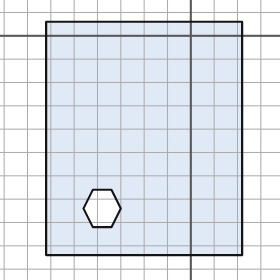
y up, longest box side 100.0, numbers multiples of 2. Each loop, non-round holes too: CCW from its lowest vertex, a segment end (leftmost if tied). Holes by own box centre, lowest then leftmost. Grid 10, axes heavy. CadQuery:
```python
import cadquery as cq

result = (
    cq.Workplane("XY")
    .moveTo(-62.0, -94.0)
    .lineTo(22.0, -94.0)
    .lineTo(22.0, 6.0)
    .lineTo(-62.0, 6.0)
    .close()
    .moveTo(-42.0, -82.0)
    .lineTo(-34.0, -82.0)
    .lineTo(-30.0, -74.0)
    .lineTo(-34.0, -66.0)
    .lineTo(-42.0, -66.0)
    .lineTo(-46.0, -74.0)
    .close()
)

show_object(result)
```